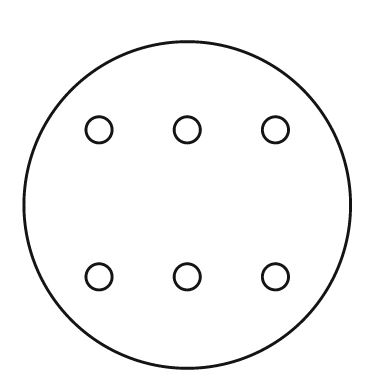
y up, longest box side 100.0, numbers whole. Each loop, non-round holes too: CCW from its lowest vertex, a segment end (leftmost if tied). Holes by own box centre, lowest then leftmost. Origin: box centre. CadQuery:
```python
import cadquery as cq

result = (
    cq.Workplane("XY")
    .moveTo(0.0, 0.0)
    .circle(50.0)
    .moveTo(-27.0, -22.0)
    .circle(4.0)
    .moveTo(0.0, -22.0)
    .circle(4.0)
    .moveTo(27.0, -22.0)
    .circle(4.0)
    .moveTo(-27.0, 23.0)
    .circle(4.0)
    .moveTo(0.0, 23.0)
    .circle(4.0)
    .moveTo(27.0, 23.0)
    .circle(4.0)
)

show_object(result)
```